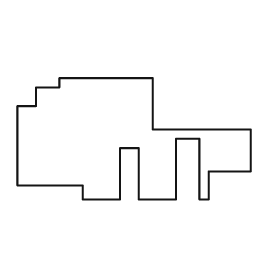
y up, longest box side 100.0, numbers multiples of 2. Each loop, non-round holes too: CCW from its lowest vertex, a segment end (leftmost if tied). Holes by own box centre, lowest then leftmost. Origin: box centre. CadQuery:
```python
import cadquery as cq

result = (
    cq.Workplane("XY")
    .moveTo(-22.0, -26.0)
    .lineTo(-6.0, -26.0)
    .lineTo(-6.0, -4.0)
    .lineTo(2.0, -4.0)
    .lineTo(2.0, -26.0)
    .lineTo(18.0, -26.0)
    .lineTo(18.0, 0.0)
    .lineTo(28.0, 0.0)
    .lineTo(28.0, -26.0)
    .lineTo(32.0, -26.0)
    .lineTo(32.0, -14.0)
    .lineTo(50.0, -14.0)
    .lineTo(50.0, 4.0)
    .lineTo(8.0, 4.0)
    .lineTo(8.0, 26.0)
    .lineTo(-32.0, 26.0)
    .lineTo(-32.0, 22.0)
    .lineTo(-42.0, 22.0)
    .lineTo(-42.0, 14.0)
    .lineTo(-50.0, 14.0)
    .lineTo(-50.0, -20.0)
    .lineTo(-22.0, -20.0)
    .close()
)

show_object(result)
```